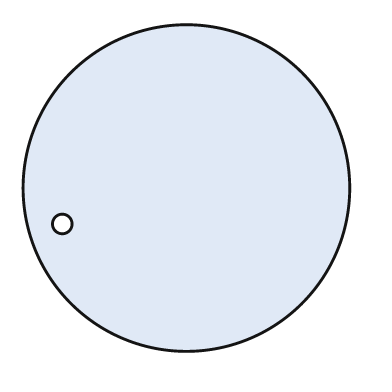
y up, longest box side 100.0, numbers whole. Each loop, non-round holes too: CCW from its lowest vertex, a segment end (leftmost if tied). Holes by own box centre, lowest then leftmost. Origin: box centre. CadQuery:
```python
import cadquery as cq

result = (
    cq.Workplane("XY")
    .moveTo(0.0, 0.0)
    .circle(50.0)
    .moveTo(-38.0, -11.0)
    .circle(3.0)
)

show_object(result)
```